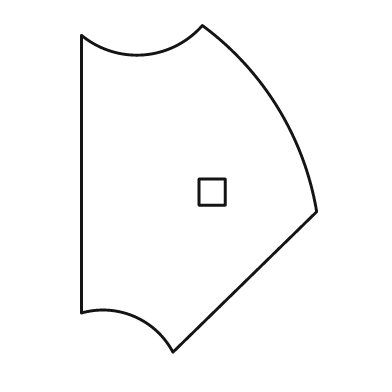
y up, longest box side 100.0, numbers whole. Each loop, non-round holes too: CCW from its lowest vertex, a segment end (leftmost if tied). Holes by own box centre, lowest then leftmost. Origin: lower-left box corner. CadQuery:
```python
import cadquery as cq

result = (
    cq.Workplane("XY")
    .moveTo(28.0, 0.0)
    .lineTo(72.0, 43.0)
    .threePointArc((60.0, 75.0), (37.0, 100.0))
    .threePointArc((19.0, 91.0), (0.0, 97.0))
    .lineTo(0.0, 12.0)
    .threePointArc((16.0, 11.0), (28.0, 0.0))
    .close()
    .moveTo(36.0, 45.0)
    .lineTo(44.0, 45.0)
    .lineTo(44.0, 53.0)
    .lineTo(36.0, 53.0)
    .close()
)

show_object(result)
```